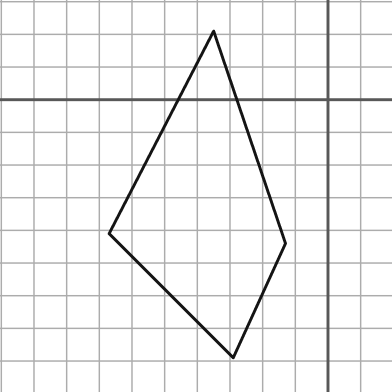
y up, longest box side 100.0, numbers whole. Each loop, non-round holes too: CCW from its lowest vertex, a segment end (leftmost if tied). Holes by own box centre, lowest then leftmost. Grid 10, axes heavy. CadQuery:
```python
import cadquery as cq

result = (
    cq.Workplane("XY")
    .moveTo(-29.0, -79.0)
    .lineTo(-13.0, -44.0)
    .lineTo(-35.0, 21.0)
    .lineTo(-67.0, -41.0)
    .close()
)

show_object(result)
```